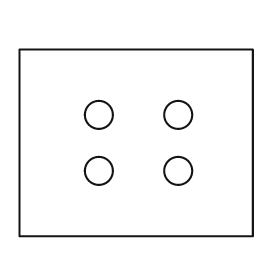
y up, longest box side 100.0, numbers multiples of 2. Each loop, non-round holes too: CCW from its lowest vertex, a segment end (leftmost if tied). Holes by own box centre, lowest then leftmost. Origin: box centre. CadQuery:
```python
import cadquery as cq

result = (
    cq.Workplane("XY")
    .moveTo(-50.0, -40.0)
    .lineTo(50.0, -40.0)
    .lineTo(50.0, 40.0)
    .lineTo(-50.0, 40.0)
    .close()
    .moveTo(-16.0, -12.0)
    .circle(6.0)
    .moveTo(18.0, -12.0)
    .circle(6.0)
    .moveTo(-16.0, 12.0)
    .circle(6.0)
    .moveTo(18.0, 12.0)
    .circle(6.0)
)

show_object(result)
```